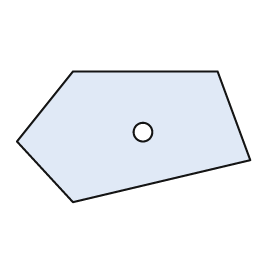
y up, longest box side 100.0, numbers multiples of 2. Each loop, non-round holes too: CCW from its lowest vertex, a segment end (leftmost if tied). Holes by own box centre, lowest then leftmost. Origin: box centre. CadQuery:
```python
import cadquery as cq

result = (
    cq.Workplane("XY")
    .moveTo(-26.0, -28.0)
    .lineTo(50.0, -10.0)
    .lineTo(36.0, 28.0)
    .lineTo(-26.0, 28.0)
    .lineTo(-50.0, -2.0)
    .close()
    .moveTo(4.0, 2.0)
    .circle(4.0)
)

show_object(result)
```